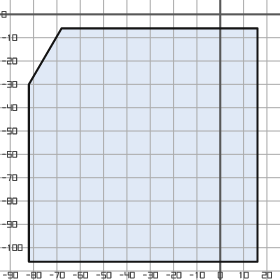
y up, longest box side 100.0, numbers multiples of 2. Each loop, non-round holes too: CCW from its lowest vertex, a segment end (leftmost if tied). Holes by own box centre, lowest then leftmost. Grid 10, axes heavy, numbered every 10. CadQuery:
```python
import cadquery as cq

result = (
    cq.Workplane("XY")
    .moveTo(-82.0, -106.0)
    .lineTo(16.0, -106.0)
    .lineTo(16.0, -6.0)
    .lineTo(-68.0, -6.0)
    .lineTo(-82.0, -30.0)
    .close()
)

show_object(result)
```